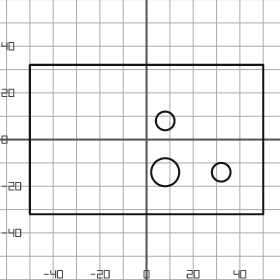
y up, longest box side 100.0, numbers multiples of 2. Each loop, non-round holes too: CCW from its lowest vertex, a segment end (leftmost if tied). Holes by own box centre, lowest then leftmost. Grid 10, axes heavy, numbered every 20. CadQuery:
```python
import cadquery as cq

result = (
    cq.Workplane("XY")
    .moveTo(-50.0, -32.0)
    .lineTo(50.0, -32.0)
    .lineTo(50.0, 32.0)
    .lineTo(-50.0, 32.0)
    .close()
    .moveTo(8.0, -14.0)
    .circle(6.0)
    .moveTo(32.0, -14.0)
    .circle(4.0)
    .moveTo(8.0, 8.0)
    .circle(4.0)
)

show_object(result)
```